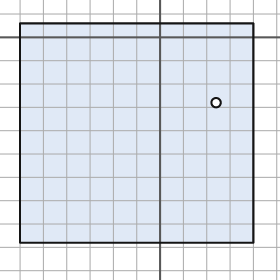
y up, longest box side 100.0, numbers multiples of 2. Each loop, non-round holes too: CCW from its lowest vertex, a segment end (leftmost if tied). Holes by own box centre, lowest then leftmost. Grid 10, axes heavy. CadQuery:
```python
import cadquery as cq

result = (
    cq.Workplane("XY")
    .moveTo(-60.0, -88.0)
    .lineTo(40.0, -88.0)
    .lineTo(40.0, 6.0)
    .lineTo(-60.0, 6.0)
    .close()
    .moveTo(24.0, -28.0)
    .circle(2.0)
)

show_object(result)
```